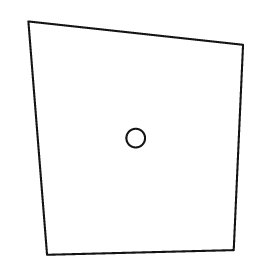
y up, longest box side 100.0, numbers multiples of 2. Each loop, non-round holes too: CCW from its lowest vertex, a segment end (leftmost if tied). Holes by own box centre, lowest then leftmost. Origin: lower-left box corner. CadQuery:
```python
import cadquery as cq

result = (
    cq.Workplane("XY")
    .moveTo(8.0, 0.0)
    .lineTo(88.0, 2.0)
    .lineTo(92.0, 90.0)
    .lineTo(0.0, 100.0)
    .close()
    .moveTo(46.0, 50.0)
    .circle(4.0)
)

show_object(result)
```